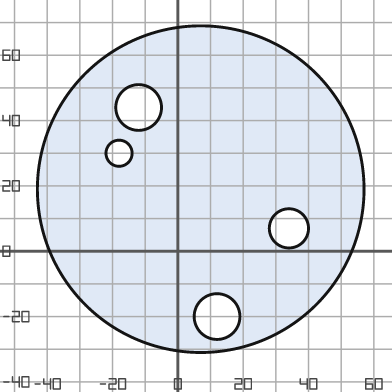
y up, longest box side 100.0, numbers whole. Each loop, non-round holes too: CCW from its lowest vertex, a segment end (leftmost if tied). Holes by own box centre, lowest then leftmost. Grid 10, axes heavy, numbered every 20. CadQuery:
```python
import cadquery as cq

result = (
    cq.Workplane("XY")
    .moveTo(7.0, 19.0)
    .circle(50.0)
    .moveTo(12.0, -20.0)
    .circle(7.0)
    .moveTo(34.0, 7.0)
    .circle(6.0)
    .moveTo(-18.0, 30.0)
    .circle(4.0)
    .moveTo(-12.0, 44.0)
    .circle(7.0)
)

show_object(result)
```